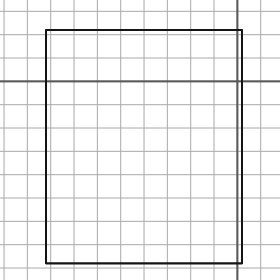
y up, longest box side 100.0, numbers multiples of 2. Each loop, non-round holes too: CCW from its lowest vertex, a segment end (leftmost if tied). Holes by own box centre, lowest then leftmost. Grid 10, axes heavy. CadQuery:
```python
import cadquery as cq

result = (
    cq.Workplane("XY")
    .moveTo(-82.0, -78.0)
    .lineTo(2.0, -78.0)
    .lineTo(2.0, 22.0)
    .lineTo(-82.0, 22.0)
    .close()
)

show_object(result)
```